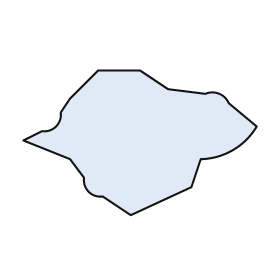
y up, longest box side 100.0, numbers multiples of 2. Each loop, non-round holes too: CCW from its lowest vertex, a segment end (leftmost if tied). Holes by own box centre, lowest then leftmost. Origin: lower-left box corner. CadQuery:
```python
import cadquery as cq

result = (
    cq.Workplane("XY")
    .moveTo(46.0, 0.0)
    .lineTo(72.0, 12.0)
    .lineTo(76.0, 24.0)
    .threePointArc((90.0, 28.0), (100.0, 38.0))
    .lineTo(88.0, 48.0)
    .threePointArc((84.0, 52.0), (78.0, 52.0))
    .lineTo(62.0, 54.0)
    .lineTo(50.0, 62.0)
    .lineTo(32.0, 62.0)
    .lineTo(20.0, 50.0)
    .lineTo(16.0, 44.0)
    .threePointArc((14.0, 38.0), (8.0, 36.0))
    .lineTo(0.0, 32.0)
    .lineTo(20.0, 24.0)
    .lineTo(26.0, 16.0)
    .threePointArc((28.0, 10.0), (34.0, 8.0))
    .close()
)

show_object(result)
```